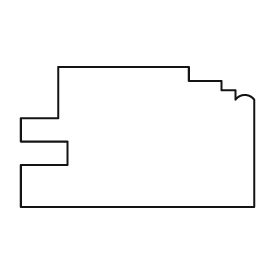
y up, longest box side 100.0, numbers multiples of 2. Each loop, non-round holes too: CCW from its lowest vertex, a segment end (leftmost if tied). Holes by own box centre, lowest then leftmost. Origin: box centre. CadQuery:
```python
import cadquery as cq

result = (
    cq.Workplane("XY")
    .moveTo(-50.0, -30.0)
    .lineTo(50.0, -30.0)
    .lineTo(50.0, 16.0)
    .threePointArc((46.0, 18.0), (42.0, 16.0))
    .lineTo(42.0, 20.0)
    .lineTo(36.0, 20.0)
    .lineTo(36.0, 24.0)
    .lineTo(22.0, 24.0)
    .lineTo(22.0, 30.0)
    .lineTo(-34.0, 30.0)
    .lineTo(-34.0, 8.0)
    .lineTo(-50.0, 8.0)
    .lineTo(-50.0, -2.0)
    .lineTo(-30.0, -2.0)
    .lineTo(-30.0, -12.0)
    .lineTo(-50.0, -12.0)
    .close()
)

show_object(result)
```